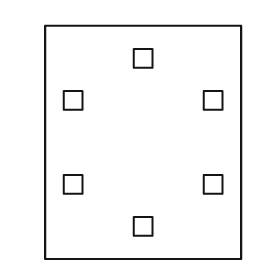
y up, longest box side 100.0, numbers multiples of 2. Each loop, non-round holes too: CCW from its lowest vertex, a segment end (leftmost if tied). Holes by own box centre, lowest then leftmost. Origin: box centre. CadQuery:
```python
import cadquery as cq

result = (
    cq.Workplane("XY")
    .moveTo(-42.0, -50.0)
    .lineTo(42.0, -50.0)
    .lineTo(42.0, 50.0)
    .lineTo(-42.0, 50.0)
    .close()
    .moveTo(-4.0, -40.0)
    .lineTo(4.0, -40.0)
    .lineTo(4.0, -32.0)
    .lineTo(-4.0, -32.0)
    .close()
    .moveTo(-34.0, -22.0)
    .lineTo(-26.0, -22.0)
    .lineTo(-26.0, -14.0)
    .lineTo(-34.0, -14.0)
    .close()
    .moveTo(26.0, -22.0)
    .lineTo(34.0, -22.0)
    .lineTo(34.0, -14.0)
    .lineTo(26.0, -14.0)
    .close()
    .moveTo(-34.0, 14.0)
    .lineTo(-26.0, 14.0)
    .lineTo(-26.0, 22.0)
    .lineTo(-34.0, 22.0)
    .close()
    .moveTo(26.0, 14.0)
    .lineTo(34.0, 14.0)
    .lineTo(34.0, 22.0)
    .lineTo(26.0, 22.0)
    .close()
    .moveTo(-4.0, 32.0)
    .lineTo(4.0, 32.0)
    .lineTo(4.0, 40.0)
    .lineTo(-4.0, 40.0)
    .close()
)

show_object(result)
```